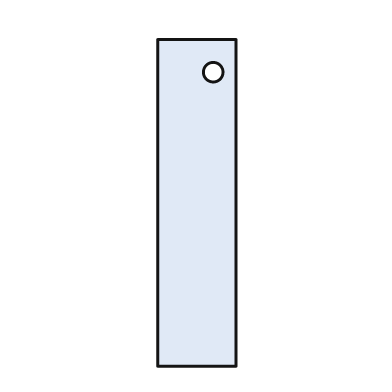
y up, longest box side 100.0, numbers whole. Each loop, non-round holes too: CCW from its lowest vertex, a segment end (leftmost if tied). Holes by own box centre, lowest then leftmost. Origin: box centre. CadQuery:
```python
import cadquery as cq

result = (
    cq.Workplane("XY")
    .moveTo(-12.0, -50.0)
    .lineTo(12.0, -50.0)
    .lineTo(12.0, 50.0)
    .lineTo(-12.0, 50.0)
    .close()
    .moveTo(5.0, 40.0)
    .circle(3.0)
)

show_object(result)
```